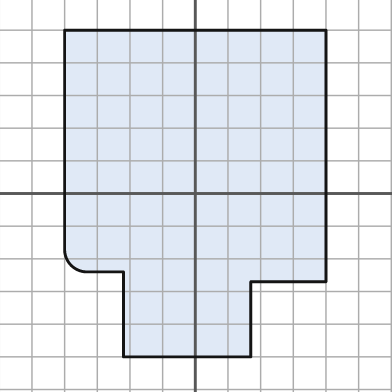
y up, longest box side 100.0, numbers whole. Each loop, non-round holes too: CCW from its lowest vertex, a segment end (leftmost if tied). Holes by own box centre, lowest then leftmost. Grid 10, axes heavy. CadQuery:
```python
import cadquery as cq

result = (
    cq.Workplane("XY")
    .moveTo(-22.0, -50.0)
    .lineTo(17.0, -50.0)
    .lineTo(17.0, -27.0)
    .lineTo(40.0, -27.0)
    .lineTo(40.0, 50.0)
    .lineTo(-40.0, 50.0)
    .lineTo(-40.0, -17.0)
    .threePointArc((-38.0, -22.0), (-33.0, -24.0))
    .lineTo(-22.0, -24.0)
    .close()
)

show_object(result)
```